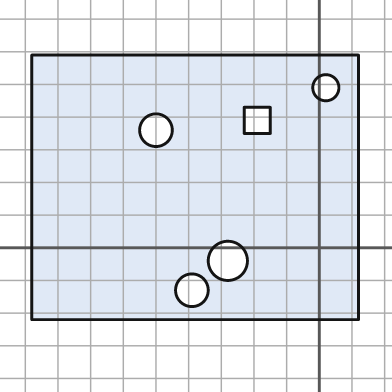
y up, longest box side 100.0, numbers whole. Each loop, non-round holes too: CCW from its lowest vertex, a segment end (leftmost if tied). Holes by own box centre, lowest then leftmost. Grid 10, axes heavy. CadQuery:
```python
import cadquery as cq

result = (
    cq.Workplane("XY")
    .moveTo(-88.0, -22.0)
    .lineTo(12.0, -22.0)
    .lineTo(12.0, 59.0)
    .lineTo(-88.0, 59.0)
    .close()
    .moveTo(-39.0, -13.0)
    .circle(5.0)
    .moveTo(-28.0, -4.0)
    .circle(6.0)
    .moveTo(-50.0, 36.0)
    .circle(5.0)
    .moveTo(-23.0, 35.0)
    .lineTo(-15.0, 35.0)
    .lineTo(-15.0, 43.0)
    .lineTo(-23.0, 43.0)
    .close()
    .moveTo(2.0, 49.0)
    .circle(4.0)
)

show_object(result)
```